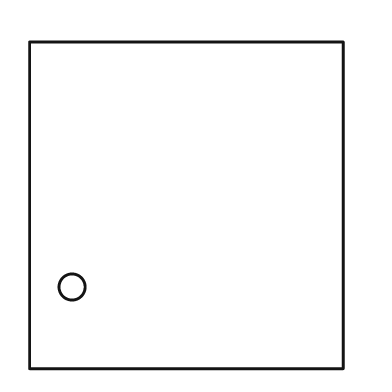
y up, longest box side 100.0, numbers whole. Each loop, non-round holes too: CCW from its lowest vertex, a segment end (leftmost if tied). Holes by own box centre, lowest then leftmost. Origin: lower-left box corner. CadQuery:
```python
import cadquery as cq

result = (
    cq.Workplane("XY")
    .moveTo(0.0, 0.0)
    .lineTo(96.0, 0.0)
    .lineTo(96.0, 100.0)
    .lineTo(0.0, 100.0)
    .close()
    .moveTo(13.0, 25.0)
    .circle(4.0)
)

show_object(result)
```